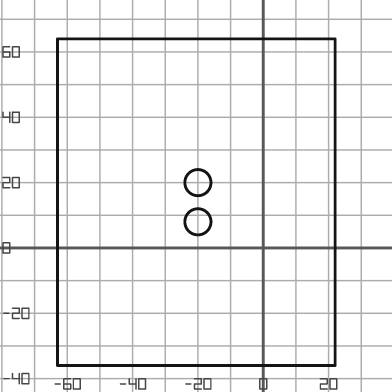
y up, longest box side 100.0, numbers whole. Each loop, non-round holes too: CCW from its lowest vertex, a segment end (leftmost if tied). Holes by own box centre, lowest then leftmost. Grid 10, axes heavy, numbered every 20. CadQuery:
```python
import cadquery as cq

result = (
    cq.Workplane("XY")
    .moveTo(-63.0, -36.0)
    .lineTo(22.0, -36.0)
    .lineTo(22.0, 64.0)
    .lineTo(-63.0, 64.0)
    .close()
    .moveTo(-20.0, 8.0)
    .circle(4.0)
    .moveTo(-20.0, 20.0)
    .circle(4.0)
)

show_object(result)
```